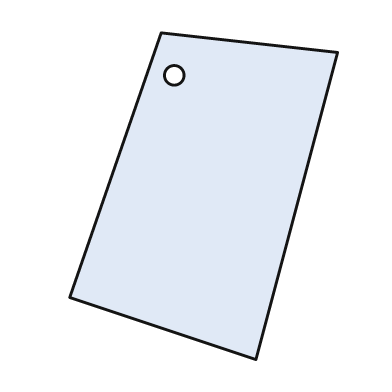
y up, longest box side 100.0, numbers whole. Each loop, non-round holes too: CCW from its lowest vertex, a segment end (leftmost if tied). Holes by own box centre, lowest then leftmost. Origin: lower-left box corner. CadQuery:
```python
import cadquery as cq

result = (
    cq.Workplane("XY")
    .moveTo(57.0, 0.0)
    .lineTo(82.0, 94.0)
    .lineTo(28.0, 100.0)
    .lineTo(0.0, 19.0)
    .close()
    .moveTo(32.0, 87.0)
    .circle(3.0)
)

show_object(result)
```